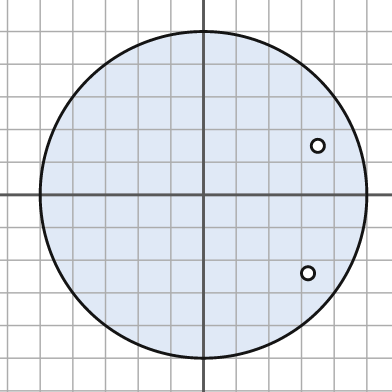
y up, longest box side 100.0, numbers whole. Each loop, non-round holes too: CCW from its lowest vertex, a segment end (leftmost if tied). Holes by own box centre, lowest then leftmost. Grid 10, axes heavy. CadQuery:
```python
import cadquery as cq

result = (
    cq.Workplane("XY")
    .moveTo(0.0, 0.0)
    .circle(50.0)
    .moveTo(32.0, -24.0)
    .circle(2.0)
    .moveTo(35.0, 15.0)
    .circle(2.0)
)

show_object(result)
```